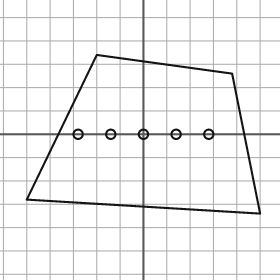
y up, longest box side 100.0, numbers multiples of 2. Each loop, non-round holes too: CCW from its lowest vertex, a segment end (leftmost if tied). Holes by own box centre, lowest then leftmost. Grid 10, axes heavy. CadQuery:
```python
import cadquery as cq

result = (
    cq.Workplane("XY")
    .moveTo(50.0, -34.0)
    .lineTo(38.0, 26.0)
    .lineTo(-20.0, 34.0)
    .lineTo(-50.0, -28.0)
    .close()
    .moveTo(-28.0, 0.0)
    .circle(2.0)
    .moveTo(-14.0, 0.0)
    .circle(2.0)
    .moveTo(0.0, 0.0)
    .circle(2.0)
    .moveTo(14.0, 0.0)
    .circle(2.0)
    .moveTo(28.0, 0.0)
    .circle(2.0)
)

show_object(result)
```